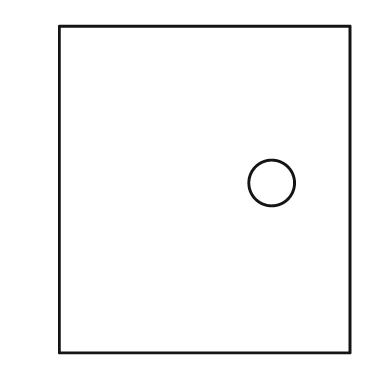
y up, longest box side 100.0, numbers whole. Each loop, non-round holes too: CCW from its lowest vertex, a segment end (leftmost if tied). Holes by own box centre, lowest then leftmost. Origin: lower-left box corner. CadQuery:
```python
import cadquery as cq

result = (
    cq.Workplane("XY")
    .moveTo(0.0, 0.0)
    .lineTo(89.0, 0.0)
    .lineTo(89.0, 100.0)
    .lineTo(0.0, 100.0)
    .close()
    .moveTo(65.0, 52.0)
    .circle(7.0)
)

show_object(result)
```